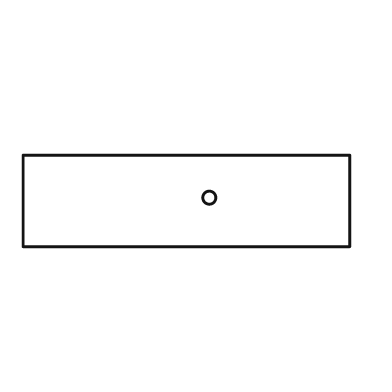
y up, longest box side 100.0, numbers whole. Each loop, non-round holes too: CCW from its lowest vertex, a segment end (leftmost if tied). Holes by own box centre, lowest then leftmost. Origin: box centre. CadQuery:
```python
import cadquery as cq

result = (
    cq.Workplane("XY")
    .moveTo(-50.0, -14.0)
    .lineTo(50.0, -14.0)
    .lineTo(50.0, 14.0)
    .lineTo(-50.0, 14.0)
    .close()
    .moveTo(7.0, 1.0)
    .circle(2.0)
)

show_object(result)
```